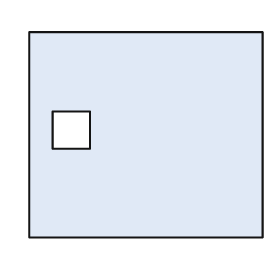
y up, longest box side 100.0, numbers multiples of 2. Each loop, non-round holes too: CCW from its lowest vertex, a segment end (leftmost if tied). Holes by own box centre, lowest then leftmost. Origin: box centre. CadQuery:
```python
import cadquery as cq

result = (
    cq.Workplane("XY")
    .moveTo(-50.0, -44.0)
    .lineTo(50.0, -44.0)
    .lineTo(50.0, 44.0)
    .lineTo(-50.0, 44.0)
    .close()
    .moveTo(-40.0, -6.0)
    .lineTo(-24.0, -6.0)
    .lineTo(-24.0, 10.0)
    .lineTo(-40.0, 10.0)
    .close()
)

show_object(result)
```